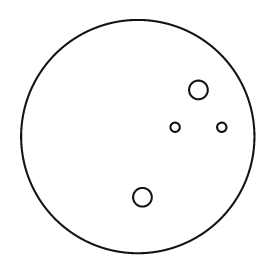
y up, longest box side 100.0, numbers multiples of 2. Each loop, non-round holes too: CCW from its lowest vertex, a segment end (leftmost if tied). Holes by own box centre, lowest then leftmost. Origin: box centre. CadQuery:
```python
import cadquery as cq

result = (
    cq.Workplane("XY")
    .moveTo(0.0, 0.0)
    .circle(50.0)
    .moveTo(2.0, -26.0)
    .circle(4.0)
    .moveTo(16.0, 4.0)
    .circle(2.0)
    .moveTo(36.0, 4.0)
    .circle(2.0)
    .moveTo(26.0, 20.0)
    .circle(4.0)
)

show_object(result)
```